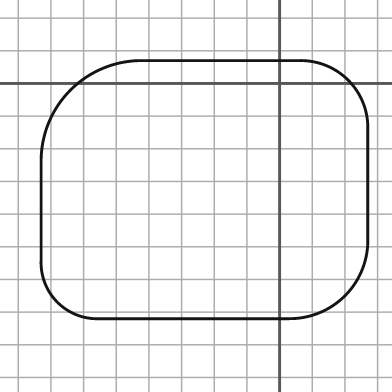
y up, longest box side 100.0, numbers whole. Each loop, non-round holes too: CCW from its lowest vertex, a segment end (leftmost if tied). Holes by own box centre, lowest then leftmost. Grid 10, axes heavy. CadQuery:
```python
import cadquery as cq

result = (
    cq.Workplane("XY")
    .moveTo(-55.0, -72.0)
    .lineTo(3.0, -72.0)
    .threePointArc((20.0, -65.0), (27.0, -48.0))
    .lineTo(27.0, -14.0)
    .threePointArc((21.0, 1.0), (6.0, 7.0))
    .lineTo(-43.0, 7.0)
    .threePointArc((-64.0, -2.0), (-73.0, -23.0))
    .lineTo(-73.0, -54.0)
    .threePointArc((-68.0, -67.0), (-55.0, -72.0))
    .close()
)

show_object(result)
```